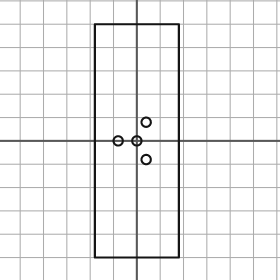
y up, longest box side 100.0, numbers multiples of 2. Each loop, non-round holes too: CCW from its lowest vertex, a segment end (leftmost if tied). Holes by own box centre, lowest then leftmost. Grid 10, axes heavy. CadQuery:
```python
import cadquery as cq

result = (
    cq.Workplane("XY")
    .moveTo(-18.0, -50.0)
    .lineTo(18.0, -50.0)
    .lineTo(18.0, 50.0)
    .lineTo(-18.0, 50.0)
    .close()
    .moveTo(4.0, -8.0)
    .circle(2.0)
    .moveTo(-8.0, 0.0)
    .circle(2.0)
    .moveTo(0.0, 0.0)
    .circle(2.0)
    .moveTo(4.0, 8.0)
    .circle(2.0)
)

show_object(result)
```